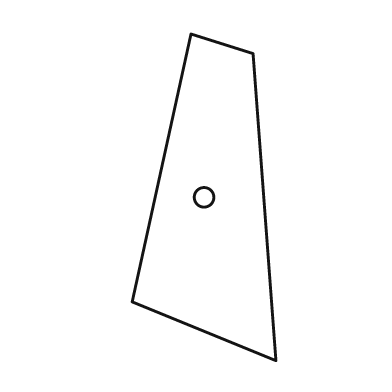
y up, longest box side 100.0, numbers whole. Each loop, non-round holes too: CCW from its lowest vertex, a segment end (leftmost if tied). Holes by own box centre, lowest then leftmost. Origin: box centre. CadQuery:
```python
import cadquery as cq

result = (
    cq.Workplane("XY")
    .moveTo(22.0, -50.0)
    .lineTo(15.0, 44.0)
    .lineTo(-4.0, 50.0)
    .lineTo(-22.0, -32.0)
    .close()
    .moveTo(0.0, 0.0)
    .circle(3.0)
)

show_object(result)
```